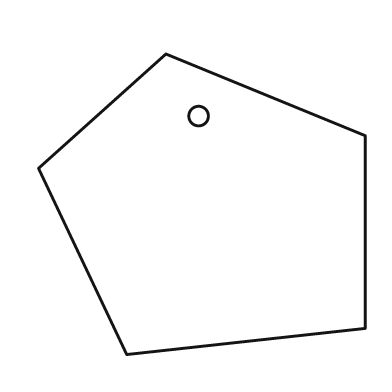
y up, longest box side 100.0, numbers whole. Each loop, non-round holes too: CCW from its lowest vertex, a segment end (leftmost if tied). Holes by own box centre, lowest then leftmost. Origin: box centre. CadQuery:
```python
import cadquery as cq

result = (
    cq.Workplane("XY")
    .moveTo(-23.0, -46.0)
    .lineTo(50.0, -38.0)
    .lineTo(50.0, 21.0)
    .lineTo(-11.0, 46.0)
    .lineTo(-50.0, 11.0)
    .close()
    .moveTo(-1.0, 27.0)
    .circle(3.0)
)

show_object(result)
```